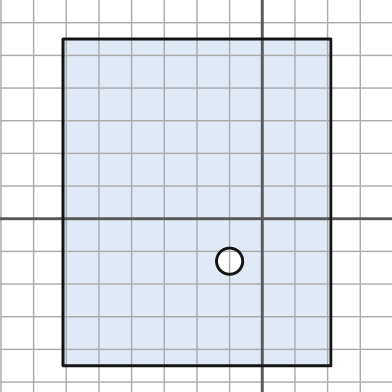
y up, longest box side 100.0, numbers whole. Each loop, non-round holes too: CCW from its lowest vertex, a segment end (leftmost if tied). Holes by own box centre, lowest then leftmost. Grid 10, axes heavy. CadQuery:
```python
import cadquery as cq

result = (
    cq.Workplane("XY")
    .moveTo(-61.0, -45.0)
    .lineTo(21.0, -45.0)
    .lineTo(21.0, 55.0)
    .lineTo(-61.0, 55.0)
    .close()
    .moveTo(-10.0, -13.0)
    .circle(4.0)
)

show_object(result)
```